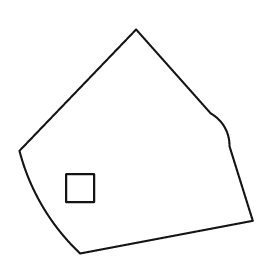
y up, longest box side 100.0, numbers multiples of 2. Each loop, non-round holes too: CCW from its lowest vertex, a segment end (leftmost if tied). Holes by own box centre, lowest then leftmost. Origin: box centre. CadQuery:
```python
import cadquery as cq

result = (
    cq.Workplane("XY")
    .moveTo(-24.0, -48.0)
    .lineTo(50.0, -34.0)
    .lineTo(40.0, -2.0)
    .threePointArc((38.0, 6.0), (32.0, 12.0))
    .lineTo(0.0, 48.0)
    .lineTo(-50.0, -4.0)
    .threePointArc((-40.0, -28.0), (-24.0, -48.0))
    .close()
    .moveTo(-30.0, -26.0)
    .lineTo(-18.0, -26.0)
    .lineTo(-18.0, -14.0)
    .lineTo(-30.0, -14.0)
    .close()
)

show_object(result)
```